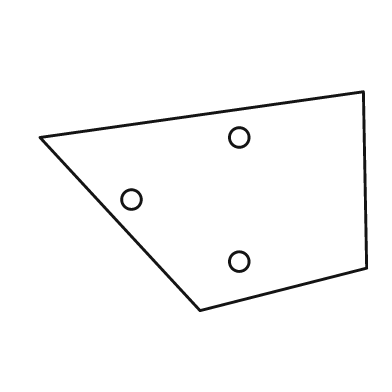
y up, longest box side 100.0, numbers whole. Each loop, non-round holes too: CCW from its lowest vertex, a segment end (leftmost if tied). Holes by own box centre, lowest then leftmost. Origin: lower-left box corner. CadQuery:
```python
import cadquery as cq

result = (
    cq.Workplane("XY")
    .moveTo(49.0, 0.0)
    .lineTo(100.0, 13.0)
    .lineTo(99.0, 67.0)
    .lineTo(0.0, 53.0)
    .close()
    .moveTo(61.0, 15.0)
    .circle(3.0)
    .moveTo(28.0, 34.0)
    .circle(3.0)
    .moveTo(61.0, 53.0)
    .circle(3.0)
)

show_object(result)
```